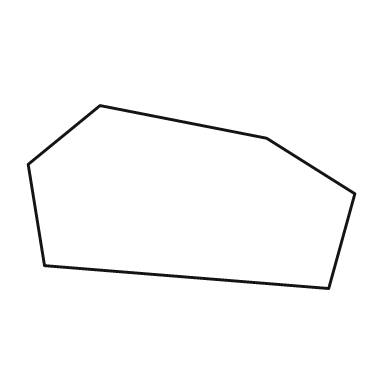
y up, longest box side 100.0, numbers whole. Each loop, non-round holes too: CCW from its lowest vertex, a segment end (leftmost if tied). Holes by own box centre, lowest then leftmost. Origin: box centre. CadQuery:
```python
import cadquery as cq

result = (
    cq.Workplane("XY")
    .moveTo(42.0, -28.0)
    .lineTo(50.0, 1.0)
    .lineTo(23.0, 18.0)
    .lineTo(-28.0, 28.0)
    .lineTo(-50.0, 10.0)
    .lineTo(-45.0, -21.0)
    .close()
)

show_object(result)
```